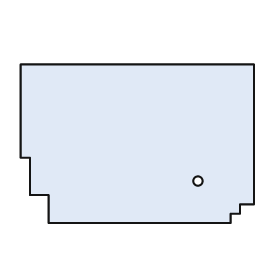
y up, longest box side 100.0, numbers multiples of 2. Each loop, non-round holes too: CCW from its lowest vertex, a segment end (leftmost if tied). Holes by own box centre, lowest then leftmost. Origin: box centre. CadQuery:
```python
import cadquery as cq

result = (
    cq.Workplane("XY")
    .moveTo(-38.0, -34.0)
    .lineTo(40.0, -34.0)
    .lineTo(40.0, -30.0)
    .lineTo(44.0, -30.0)
    .lineTo(44.0, -26.0)
    .lineTo(50.0, -26.0)
    .lineTo(50.0, 34.0)
    .lineTo(-50.0, 34.0)
    .lineTo(-50.0, -6.0)
    .lineTo(-46.0, -6.0)
    .lineTo(-46.0, -22.0)
    .lineTo(-38.0, -22.0)
    .close()
    .moveTo(26.0, -16.0)
    .circle(2.0)
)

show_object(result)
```